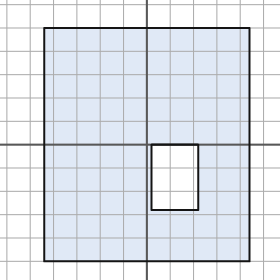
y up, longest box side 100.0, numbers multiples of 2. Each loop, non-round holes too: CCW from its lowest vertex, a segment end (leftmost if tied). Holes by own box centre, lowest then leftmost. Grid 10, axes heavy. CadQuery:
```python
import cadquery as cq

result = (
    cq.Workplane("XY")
    .moveTo(-44.0, -50.0)
    .lineTo(44.0, -50.0)
    .lineTo(44.0, 50.0)
    .lineTo(-44.0, 50.0)
    .close()
    .moveTo(2.0, -28.0)
    .lineTo(22.0, -28.0)
    .lineTo(22.0, 0.0)
    .lineTo(2.0, 0.0)
    .close()
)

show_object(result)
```